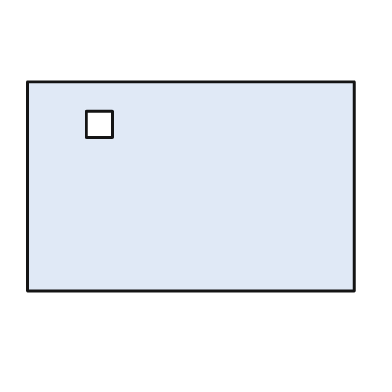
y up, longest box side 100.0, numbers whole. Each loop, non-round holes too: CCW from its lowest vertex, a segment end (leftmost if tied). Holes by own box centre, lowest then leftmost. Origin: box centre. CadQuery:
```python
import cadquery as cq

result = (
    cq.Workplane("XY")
    .moveTo(-50.0, -32.0)
    .lineTo(50.0, -32.0)
    .lineTo(50.0, 32.0)
    .lineTo(-50.0, 32.0)
    .close()
    .moveTo(-32.0, 15.0)
    .lineTo(-24.0, 15.0)
    .lineTo(-24.0, 23.0)
    .lineTo(-32.0, 23.0)
    .close()
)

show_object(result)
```